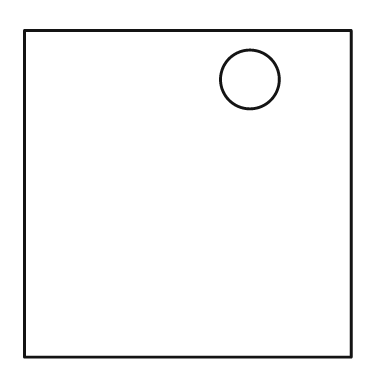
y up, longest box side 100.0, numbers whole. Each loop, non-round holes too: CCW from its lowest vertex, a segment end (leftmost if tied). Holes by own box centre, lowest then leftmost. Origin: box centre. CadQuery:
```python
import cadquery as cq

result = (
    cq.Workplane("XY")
    .moveTo(-50.0, -50.0)
    .lineTo(50.0, -50.0)
    .lineTo(50.0, 50.0)
    .lineTo(-50.0, 50.0)
    .close()
    .moveTo(19.0, 35.0)
    .circle(9.0)
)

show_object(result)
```